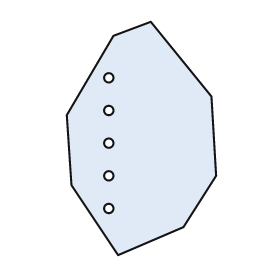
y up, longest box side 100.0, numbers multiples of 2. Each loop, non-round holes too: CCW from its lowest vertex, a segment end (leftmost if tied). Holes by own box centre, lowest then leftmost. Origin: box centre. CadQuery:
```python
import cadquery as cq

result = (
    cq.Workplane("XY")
    .moveTo(-10.0, -50.0)
    .lineTo(18.0, -38.0)
    .lineTo(32.0, -16.0)
    .lineTo(30.0, 18.0)
    .lineTo(4.0, 50.0)
    .lineTo(-12.0, 44.0)
    .lineTo(-32.0, 10.0)
    .lineTo(-30.0, -20.0)
    .close()
    .moveTo(-14.0, -30.0)
    .circle(2.0)
    .moveTo(-14.0, -16.0)
    .circle(2.0)
    .moveTo(-14.0, -2.0)
    .circle(2.0)
    .moveTo(-14.0, 12.0)
    .circle(2.0)
    .moveTo(-14.0, 26.0)
    .circle(2.0)
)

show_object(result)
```